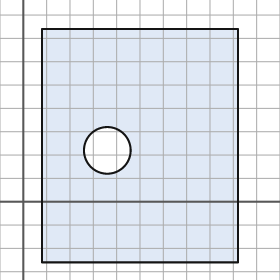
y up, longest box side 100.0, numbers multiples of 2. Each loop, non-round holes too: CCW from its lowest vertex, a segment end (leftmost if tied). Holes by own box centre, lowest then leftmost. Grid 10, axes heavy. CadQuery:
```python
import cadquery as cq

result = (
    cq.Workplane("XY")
    .moveTo(8.0, -26.0)
    .lineTo(92.0, -26.0)
    .lineTo(92.0, 74.0)
    .lineTo(8.0, 74.0)
    .close()
    .moveTo(36.0, 22.0)
    .circle(10.0)
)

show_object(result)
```